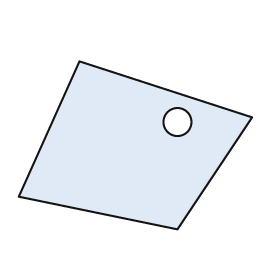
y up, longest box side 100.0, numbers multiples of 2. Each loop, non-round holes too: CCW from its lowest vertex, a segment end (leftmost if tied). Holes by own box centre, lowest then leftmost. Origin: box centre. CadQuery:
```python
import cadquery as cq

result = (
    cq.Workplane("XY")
    .moveTo(18.0, -36.0)
    .lineTo(50.0, 12.0)
    .lineTo(-24.0, 36.0)
    .lineTo(-50.0, -22.0)
    .close()
    .moveTo(18.0, 10.0)
    .circle(6.0)
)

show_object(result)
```